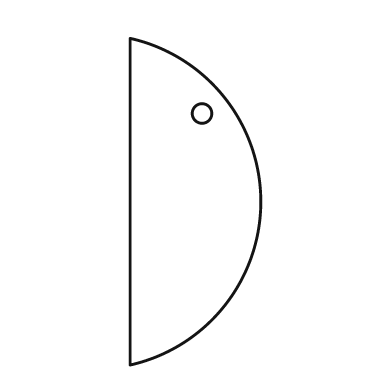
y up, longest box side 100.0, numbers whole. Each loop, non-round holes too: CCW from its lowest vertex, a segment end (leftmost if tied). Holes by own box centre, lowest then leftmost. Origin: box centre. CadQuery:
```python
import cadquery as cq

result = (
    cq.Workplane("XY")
    .moveTo(-20.0, -50.0)
    .threePointArc((20.0, 0.0), (-20.0, 50.0))
    .close()
    .moveTo(2.0, 27.0)
    .circle(3.0)
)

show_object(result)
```